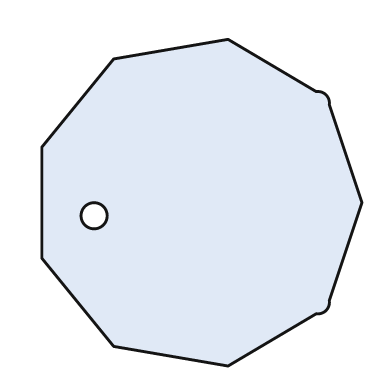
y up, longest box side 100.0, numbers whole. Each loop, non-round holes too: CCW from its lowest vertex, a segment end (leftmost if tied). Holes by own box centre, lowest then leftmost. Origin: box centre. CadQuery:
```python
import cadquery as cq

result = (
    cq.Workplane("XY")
    .moveTo(8.0, -50.0)
    .lineTo(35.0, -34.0)
    .threePointArc((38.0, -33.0), (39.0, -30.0))
    .lineTo(49.0, 0.0)
    .lineTo(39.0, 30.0)
    .threePointArc((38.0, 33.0), (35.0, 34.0))
    .lineTo(8.0, 50.0)
    .lineTo(-27.0, 44.0)
    .lineTo(-49.0, 17.0)
    .lineTo(-49.0, -17.0)
    .lineTo(-27.0, -44.0)
    .close()
    .moveTo(-33.0, -4.0)
    .circle(4.0)
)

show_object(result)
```